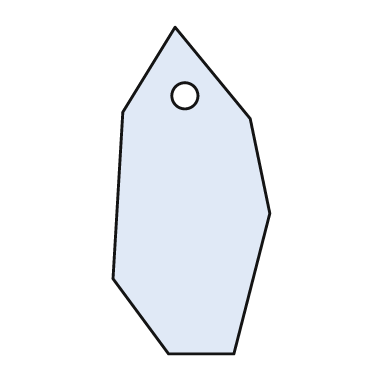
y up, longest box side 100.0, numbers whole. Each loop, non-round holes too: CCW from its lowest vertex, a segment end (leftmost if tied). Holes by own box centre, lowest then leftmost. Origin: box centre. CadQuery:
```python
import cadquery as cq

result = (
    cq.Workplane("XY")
    .moveTo(-7.0, -50.0)
    .lineTo(13.0, -50.0)
    .lineTo(24.0, -7.0)
    .lineTo(18.0, 22.0)
    .lineTo(-5.0, 50.0)
    .lineTo(-21.0, 24.0)
    .lineTo(-24.0, -27.0)
    .close()
    .moveTo(-2.0, 29.0)
    .circle(4.0)
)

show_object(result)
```